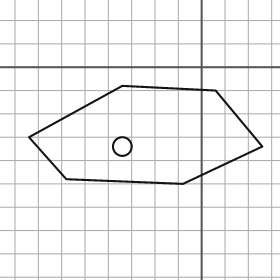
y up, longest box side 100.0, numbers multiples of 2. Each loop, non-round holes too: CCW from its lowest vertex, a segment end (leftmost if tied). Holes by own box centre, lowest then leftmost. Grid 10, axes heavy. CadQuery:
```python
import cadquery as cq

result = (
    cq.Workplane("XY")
    .moveTo(-8.0, -50.0)
    .lineTo(26.0, -34.0)
    .lineTo(6.0, -10.0)
    .lineTo(-34.0, -8.0)
    .lineTo(-74.0, -30.0)
    .lineTo(-58.0, -48.0)
    .close()
    .moveTo(-34.0, -34.0)
    .circle(4.0)
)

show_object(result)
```